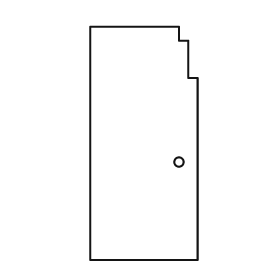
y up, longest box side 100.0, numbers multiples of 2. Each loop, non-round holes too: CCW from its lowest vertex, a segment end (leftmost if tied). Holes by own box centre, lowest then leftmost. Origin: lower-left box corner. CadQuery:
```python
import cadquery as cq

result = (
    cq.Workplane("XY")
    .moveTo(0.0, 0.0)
    .lineTo(46.0, 0.0)
    .lineTo(46.0, 78.0)
    .lineTo(42.0, 78.0)
    .lineTo(42.0, 94.0)
    .lineTo(38.0, 94.0)
    .lineTo(38.0, 100.0)
    .lineTo(0.0, 100.0)
    .close()
    .moveTo(38.0, 42.0)
    .circle(2.0)
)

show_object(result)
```